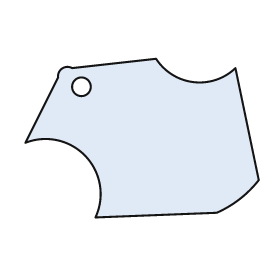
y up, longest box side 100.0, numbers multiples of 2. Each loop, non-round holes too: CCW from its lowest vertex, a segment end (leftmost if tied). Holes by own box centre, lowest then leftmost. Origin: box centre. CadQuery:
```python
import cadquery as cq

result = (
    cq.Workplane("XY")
    .moveTo(-20.0, -34.0)
    .lineTo(32.0, -32.0)
    .threePointArc((42.0, -26.0), (50.0, -18.0))
    .lineTo(40.0, 30.0)
    .threePointArc((22.0, 24.0), (6.0, 34.0))
    .lineTo(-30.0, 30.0)
    .threePointArc((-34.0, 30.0), (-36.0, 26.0))
    .lineTo(-50.0, -2.0)
    .threePointArc((-24.0, -8.0), (-20.0, -34.0))
    .close()
    .moveTo(-26.0, 22.0)
    .circle(4.0)
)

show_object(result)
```